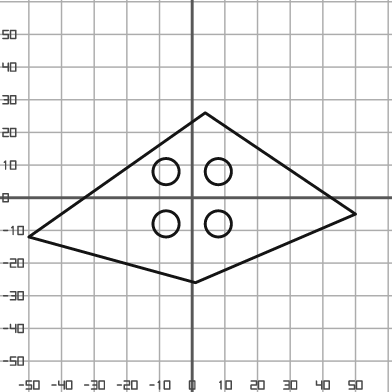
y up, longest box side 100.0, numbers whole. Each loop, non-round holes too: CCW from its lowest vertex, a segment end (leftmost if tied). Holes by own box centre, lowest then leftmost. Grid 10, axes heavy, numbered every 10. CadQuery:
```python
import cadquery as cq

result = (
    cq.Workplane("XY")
    .moveTo(1.0, -26.0)
    .lineTo(50.0, -5.0)
    .lineTo(4.0, 26.0)
    .lineTo(-50.0, -12.0)
    .close()
    .moveTo(-8.0, -8.0)
    .circle(4.0)
    .moveTo(8.0, -8.0)
    .circle(4.0)
    .moveTo(-8.0, 8.0)
    .circle(4.0)
    .moveTo(8.0, 8.0)
    .circle(4.0)
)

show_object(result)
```